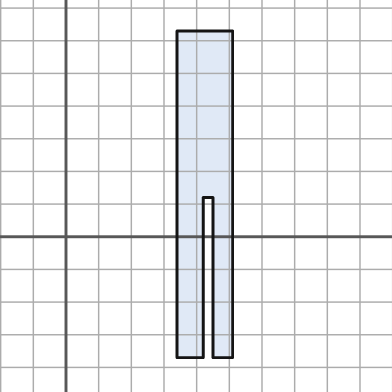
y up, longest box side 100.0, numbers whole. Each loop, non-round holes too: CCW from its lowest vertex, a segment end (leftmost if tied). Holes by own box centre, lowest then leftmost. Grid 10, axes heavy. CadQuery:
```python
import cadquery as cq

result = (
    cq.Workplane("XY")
    .moveTo(34.0, -37.0)
    .lineTo(42.0, -37.0)
    .lineTo(42.0, 12.0)
    .lineTo(45.0, 12.0)
    .lineTo(45.0, -37.0)
    .lineTo(51.0, -37.0)
    .lineTo(51.0, 63.0)
    .lineTo(34.0, 63.0)
    .close()
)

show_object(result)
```